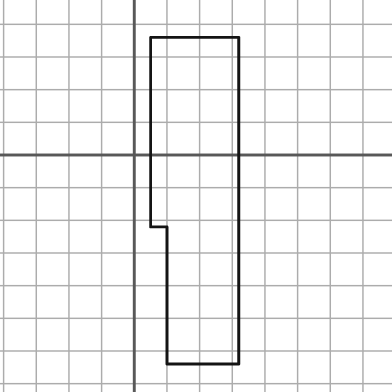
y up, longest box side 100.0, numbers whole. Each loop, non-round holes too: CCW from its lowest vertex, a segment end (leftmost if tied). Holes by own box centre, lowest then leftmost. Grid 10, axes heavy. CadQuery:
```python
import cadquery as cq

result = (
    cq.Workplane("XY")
    .moveTo(10.0, -64.0)
    .lineTo(32.0, -64.0)
    .lineTo(32.0, 36.0)
    .lineTo(5.0, 36.0)
    .lineTo(5.0, -22.0)
    .lineTo(10.0, -22.0)
    .close()
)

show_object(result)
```